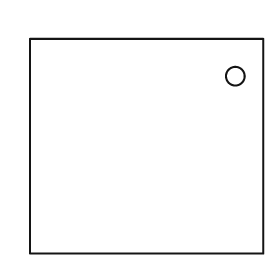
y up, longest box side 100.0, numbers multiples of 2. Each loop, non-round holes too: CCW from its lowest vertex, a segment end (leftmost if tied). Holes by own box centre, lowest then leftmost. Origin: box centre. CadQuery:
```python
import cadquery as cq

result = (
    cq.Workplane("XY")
    .moveTo(-50.0, -46.0)
    .lineTo(50.0, -46.0)
    .lineTo(50.0, 46.0)
    .lineTo(-50.0, 46.0)
    .close()
    .moveTo(38.0, 30.0)
    .circle(4.0)
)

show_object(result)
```